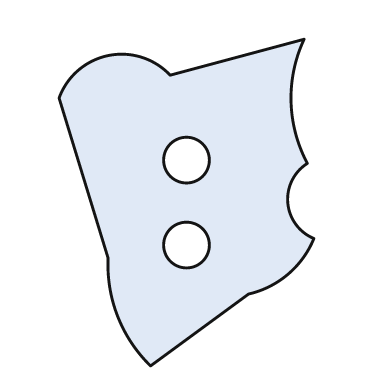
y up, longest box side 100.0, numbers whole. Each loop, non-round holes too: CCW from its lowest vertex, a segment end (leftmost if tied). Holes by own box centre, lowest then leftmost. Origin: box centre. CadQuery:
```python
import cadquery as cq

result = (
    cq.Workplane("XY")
    .moveTo(-11.0, -50.0)
    .lineTo(19.0, -28.0)
    .threePointArc((31.0, -22.0), (39.0, -11.0))
    .threePointArc((31.0, 0.0), (37.0, 12.0))
    .threePointArc((32.0, 31.0), (36.0, 50.0))
    .lineTo(-5.0, 39.0)
    .threePointArc((-24.0, 45.0), (-39.0, 32.0))
    .lineTo(-24.0, -17.0)
    .threePointArc((-21.0, -35.0), (-11.0, -50.0))
    .close()
    .moveTo(0.0, -13.0)
    .circle(7.0)
    .moveTo(0.0, 13.0)
    .circle(7.0)
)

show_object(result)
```